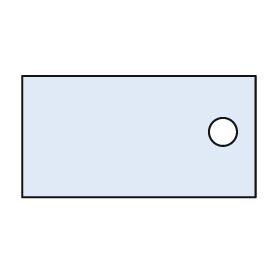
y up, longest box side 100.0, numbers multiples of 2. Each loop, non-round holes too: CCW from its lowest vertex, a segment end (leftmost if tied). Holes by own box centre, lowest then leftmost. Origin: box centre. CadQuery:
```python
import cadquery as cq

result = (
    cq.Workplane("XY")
    .moveTo(-50.0, -26.0)
    .lineTo(50.0, -26.0)
    .lineTo(50.0, 26.0)
    .lineTo(-50.0, 26.0)
    .close()
    .moveTo(36.0, 2.0)
    .circle(6.0)
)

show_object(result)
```